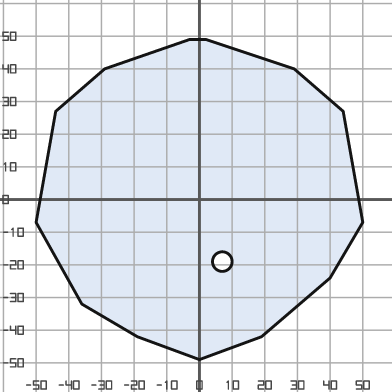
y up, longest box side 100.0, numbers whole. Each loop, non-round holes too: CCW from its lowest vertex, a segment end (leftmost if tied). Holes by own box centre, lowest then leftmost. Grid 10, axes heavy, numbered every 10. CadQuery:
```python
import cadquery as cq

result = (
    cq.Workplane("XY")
    .moveTo(0.0, -49.0)
    .lineTo(19.0, -42.0)
    .lineTo(40.0, -24.0)
    .lineTo(50.0, -7.0)
    .lineTo(44.0, 27.0)
    .lineTo(29.0, 40.0)
    .lineTo(2.0, 49.0)
    .lineTo(-3.0, 49.0)
    .lineTo(-29.0, 40.0)
    .lineTo(-44.0, 27.0)
    .lineTo(-50.0, -7.0)
    .lineTo(-36.0, -32.0)
    .lineTo(-19.0, -42.0)
    .close()
    .moveTo(7.0, -19.0)
    .circle(3.0)
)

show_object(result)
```